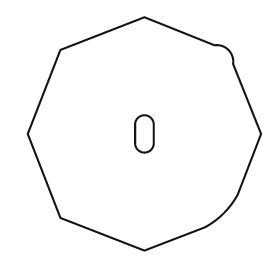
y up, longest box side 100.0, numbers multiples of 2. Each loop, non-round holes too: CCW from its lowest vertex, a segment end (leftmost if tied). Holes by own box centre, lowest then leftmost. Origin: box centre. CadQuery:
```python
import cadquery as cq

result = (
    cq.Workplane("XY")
    .moveTo(0.0, -50.0)
    .lineTo(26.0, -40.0)
    .threePointArc((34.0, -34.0), (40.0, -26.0))
    .lineTo(50.0, 0.0)
    .lineTo(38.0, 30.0)
    .threePointArc((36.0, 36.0), (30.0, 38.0))
    .lineTo(0.0, 50.0)
    .lineTo(-36.0, 36.0)
    .lineTo(-50.0, 0.0)
    .lineTo(-36.0, -36.0)
    .close()
    .moveTo(-4.0, -4.0)
    .threePointArc((0.0, -8.0), (4.0, -4.0))
    .lineTo(4.0, 4.0)
    .threePointArc((0.0, 8.0), (-4.0, 4.0))
    .close()
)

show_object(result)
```